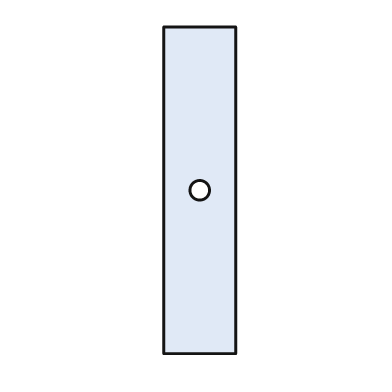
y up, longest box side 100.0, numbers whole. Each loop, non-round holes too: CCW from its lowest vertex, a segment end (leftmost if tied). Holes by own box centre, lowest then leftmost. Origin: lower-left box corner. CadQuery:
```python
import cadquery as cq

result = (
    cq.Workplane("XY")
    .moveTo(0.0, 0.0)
    .lineTo(22.0, 0.0)
    .lineTo(22.0, 100.0)
    .lineTo(0.0, 100.0)
    .close()
    .moveTo(11.0, 50.0)
    .circle(3.0)
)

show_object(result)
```